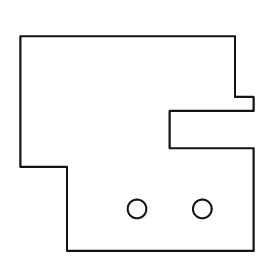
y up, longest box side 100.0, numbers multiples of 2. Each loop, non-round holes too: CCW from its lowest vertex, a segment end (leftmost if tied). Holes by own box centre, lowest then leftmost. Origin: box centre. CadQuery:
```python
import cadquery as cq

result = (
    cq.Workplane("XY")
    .moveTo(-30.0, -46.0)
    .lineTo(50.0, -46.0)
    .lineTo(50.0, -2.0)
    .lineTo(14.0, -2.0)
    .lineTo(14.0, 14.0)
    .lineTo(50.0, 14.0)
    .lineTo(50.0, 20.0)
    .lineTo(42.0, 20.0)
    .lineTo(42.0, 46.0)
    .lineTo(-50.0, 46.0)
    .lineTo(-50.0, -10.0)
    .lineTo(-30.0, -10.0)
    .close()
    .moveTo(0.0, -28.0)
    .circle(4.0)
    .moveTo(28.0, -28.0)
    .circle(4.0)
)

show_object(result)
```